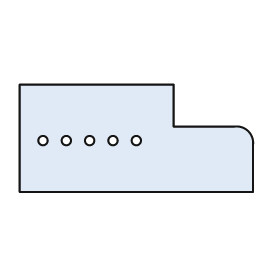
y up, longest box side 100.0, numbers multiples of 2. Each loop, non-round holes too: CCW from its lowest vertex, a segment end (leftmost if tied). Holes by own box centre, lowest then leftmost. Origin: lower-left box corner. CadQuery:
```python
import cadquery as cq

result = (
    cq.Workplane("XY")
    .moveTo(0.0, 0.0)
    .lineTo(100.0, 0.0)
    .lineTo(100.0, 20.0)
    .threePointArc((98.0, 26.0), (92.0, 28.0))
    .lineTo(66.0, 28.0)
    .lineTo(66.0, 46.0)
    .lineTo(0.0, 46.0)
    .close()
    .moveTo(10.0, 22.0)
    .circle(2.0)
    .moveTo(20.0, 22.0)
    .circle(2.0)
    .moveTo(30.0, 22.0)
    .circle(2.0)
    .moveTo(40.0, 22.0)
    .circle(2.0)
    .moveTo(50.0, 22.0)
    .circle(2.0)
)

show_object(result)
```